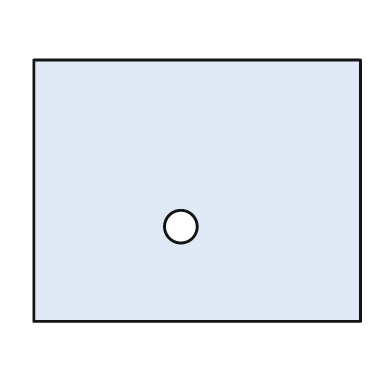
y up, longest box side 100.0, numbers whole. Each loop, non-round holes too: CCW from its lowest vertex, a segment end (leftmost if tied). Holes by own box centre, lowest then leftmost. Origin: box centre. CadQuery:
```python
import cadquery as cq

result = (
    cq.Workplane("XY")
    .moveTo(-50.0, -40.0)
    .lineTo(50.0, -40.0)
    .lineTo(50.0, 40.0)
    .lineTo(-50.0, 40.0)
    .close()
    .moveTo(-5.0, -11.0)
    .circle(5.0)
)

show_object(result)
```